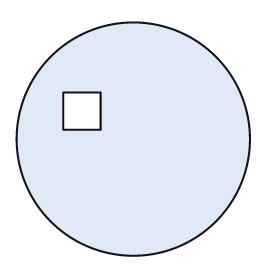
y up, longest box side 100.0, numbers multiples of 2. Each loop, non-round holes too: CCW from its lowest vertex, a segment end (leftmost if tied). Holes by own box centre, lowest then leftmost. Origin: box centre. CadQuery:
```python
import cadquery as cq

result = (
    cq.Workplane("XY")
    .moveTo(0.0, 0.0)
    .circle(50.0)
    .moveTo(-30.0, 4.0)
    .lineTo(-14.0, 4.0)
    .lineTo(-14.0, 20.0)
    .lineTo(-30.0, 20.0)
    .close()
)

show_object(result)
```